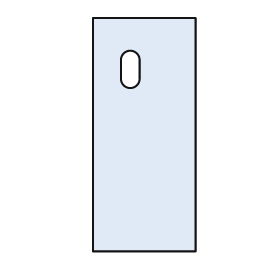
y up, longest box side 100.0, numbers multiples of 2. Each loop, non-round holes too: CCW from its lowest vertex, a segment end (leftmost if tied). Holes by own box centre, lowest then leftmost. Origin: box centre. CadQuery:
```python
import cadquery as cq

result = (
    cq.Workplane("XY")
    .moveTo(-22.0, -50.0)
    .lineTo(22.0, -50.0)
    .lineTo(22.0, 50.0)
    .lineTo(-22.0, 50.0)
    .close()
    .moveTo(-10.0, 24.0)
    .threePointArc((-6.0, 20.0), (-2.0, 24.0))
    .lineTo(-2.0, 32.0)
    .threePointArc((-6.0, 36.0), (-10.0, 32.0))
    .close()
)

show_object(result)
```